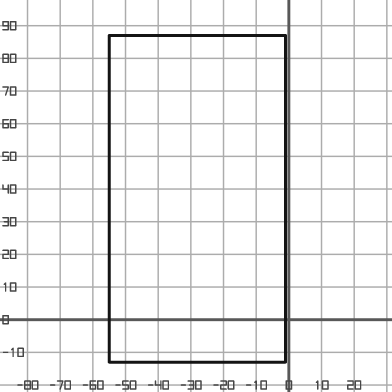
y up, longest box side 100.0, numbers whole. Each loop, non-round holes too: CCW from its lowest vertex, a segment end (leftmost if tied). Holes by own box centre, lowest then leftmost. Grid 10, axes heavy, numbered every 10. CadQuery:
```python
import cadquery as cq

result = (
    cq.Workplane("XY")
    .moveTo(-55.0, -13.0)
    .lineTo(-1.0, -13.0)
    .lineTo(-1.0, 87.0)
    .lineTo(-55.0, 87.0)
    .close()
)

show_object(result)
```